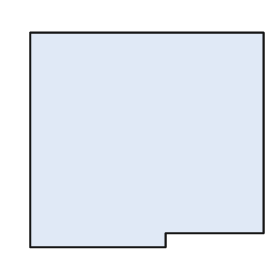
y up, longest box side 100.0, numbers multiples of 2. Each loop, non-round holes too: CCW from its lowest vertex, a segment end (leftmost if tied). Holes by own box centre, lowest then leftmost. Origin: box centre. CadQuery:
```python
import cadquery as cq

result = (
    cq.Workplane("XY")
    .moveTo(-50.0, -46.0)
    .lineTo(8.0, -46.0)
    .lineTo(8.0, -40.0)
    .lineTo(50.0, -40.0)
    .lineTo(50.0, 46.0)
    .lineTo(-50.0, 46.0)
    .close()
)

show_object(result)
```